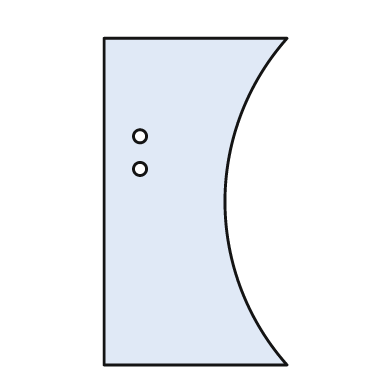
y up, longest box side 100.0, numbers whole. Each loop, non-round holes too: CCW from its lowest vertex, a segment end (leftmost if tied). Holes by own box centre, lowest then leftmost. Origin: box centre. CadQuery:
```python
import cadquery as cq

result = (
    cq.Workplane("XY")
    .moveTo(-28.0, -50.0)
    .lineTo(28.0, -50.0)
    .threePointArc((9.0, 0.0), (28.0, 50.0))
    .lineTo(-28.0, 50.0)
    .close()
    .moveTo(-17.0, 10.0)
    .circle(2.0)
    .moveTo(-17.0, 20.0)
    .circle(2.0)
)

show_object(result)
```